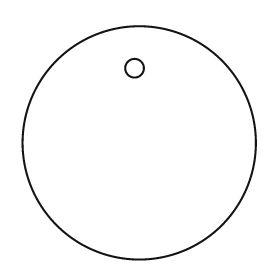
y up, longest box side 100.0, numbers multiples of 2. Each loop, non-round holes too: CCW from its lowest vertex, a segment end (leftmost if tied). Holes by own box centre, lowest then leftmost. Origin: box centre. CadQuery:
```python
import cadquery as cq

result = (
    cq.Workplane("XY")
    .moveTo(0.0, 0.0)
    .circle(50.0)
    .moveTo(-2.0, 32.0)
    .circle(4.0)
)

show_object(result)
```